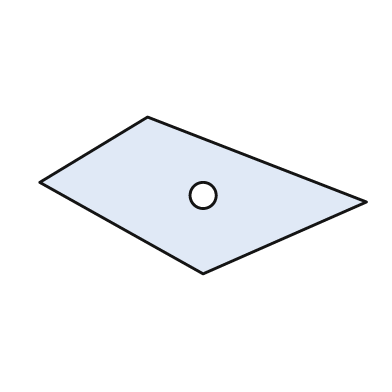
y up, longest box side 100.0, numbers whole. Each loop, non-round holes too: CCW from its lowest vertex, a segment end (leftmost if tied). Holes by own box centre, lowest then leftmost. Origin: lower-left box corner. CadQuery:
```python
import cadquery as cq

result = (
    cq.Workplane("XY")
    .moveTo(50.0, 0.0)
    .lineTo(100.0, 22.0)
    .lineTo(33.0, 48.0)
    .lineTo(0.0, 28.0)
    .close()
    .moveTo(50.0, 24.0)
    .circle(4.0)
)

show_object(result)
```